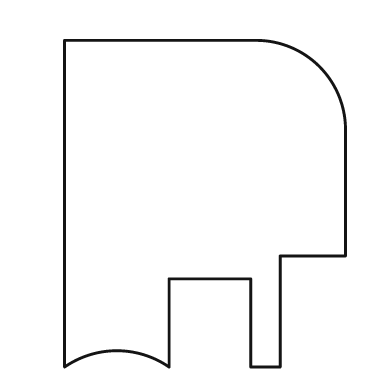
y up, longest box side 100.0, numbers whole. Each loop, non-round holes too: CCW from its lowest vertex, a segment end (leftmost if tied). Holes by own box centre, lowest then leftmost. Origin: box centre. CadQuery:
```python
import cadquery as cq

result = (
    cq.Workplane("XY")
    .moveTo(-43.0, -50.0)
    .threePointArc((-27.0, -45.0), (-11.0, -50.0))
    .lineTo(-11.0, -23.0)
    .lineTo(14.0, -23.0)
    .lineTo(14.0, -50.0)
    .lineTo(23.0, -50.0)
    .lineTo(23.0, -16.0)
    .lineTo(43.0, -16.0)
    .lineTo(43.0, 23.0)
    .threePointArc((35.0, 42.0), (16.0, 50.0))
    .lineTo(-43.0, 50.0)
    .close()
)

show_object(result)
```